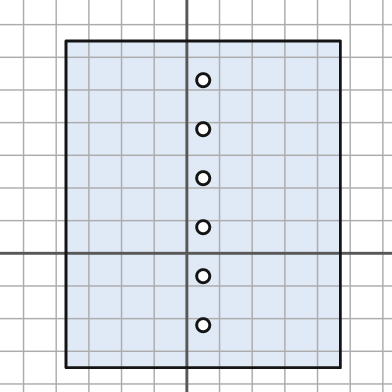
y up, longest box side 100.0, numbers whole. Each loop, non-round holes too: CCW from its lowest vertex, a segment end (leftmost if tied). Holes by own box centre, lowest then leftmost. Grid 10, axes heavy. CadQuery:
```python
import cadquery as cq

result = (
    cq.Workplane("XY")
    .moveTo(-37.0, -35.0)
    .lineTo(47.0, -35.0)
    .lineTo(47.0, 65.0)
    .lineTo(-37.0, 65.0)
    .close()
    .moveTo(5.0, -22.0)
    .circle(2.0)
    .moveTo(5.0, -7.0)
    .circle(2.0)
    .moveTo(5.0, 8.0)
    .circle(2.0)
    .moveTo(5.0, 23.0)
    .circle(2.0)
    .moveTo(5.0, 38.0)
    .circle(2.0)
    .moveTo(5.0, 53.0)
    .circle(2.0)
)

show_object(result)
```